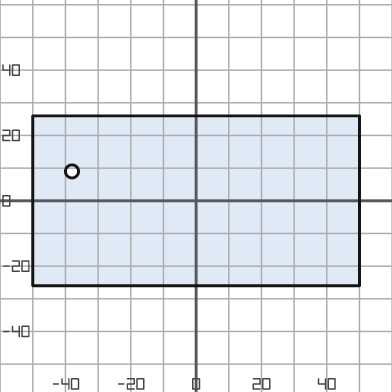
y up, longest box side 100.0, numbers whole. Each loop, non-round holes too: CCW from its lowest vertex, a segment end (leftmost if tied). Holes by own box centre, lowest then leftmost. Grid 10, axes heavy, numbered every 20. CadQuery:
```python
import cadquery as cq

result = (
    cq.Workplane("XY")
    .moveTo(-50.0, -26.0)
    .lineTo(50.0, -26.0)
    .lineTo(50.0, 26.0)
    .lineTo(-50.0, 26.0)
    .close()
    .moveTo(-38.0, 9.0)
    .circle(2.0)
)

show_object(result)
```